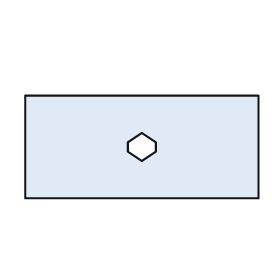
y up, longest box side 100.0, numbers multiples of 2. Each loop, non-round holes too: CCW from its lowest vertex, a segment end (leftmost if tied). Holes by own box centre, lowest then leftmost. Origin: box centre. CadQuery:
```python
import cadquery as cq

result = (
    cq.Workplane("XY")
    .moveTo(-50.0, -22.0)
    .lineTo(50.0, -22.0)
    .lineTo(50.0, 22.0)
    .lineTo(-50.0, 22.0)
    .close()
    .moveTo(0.0, -6.0)
    .lineTo(6.0, -2.0)
    .lineTo(6.0, 2.0)
    .lineTo(0.0, 6.0)
    .lineTo(-6.0, 2.0)
    .lineTo(-6.0, -2.0)
    .close()
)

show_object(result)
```